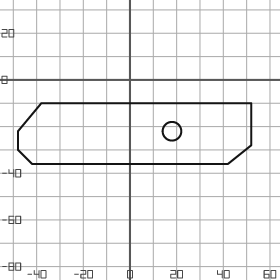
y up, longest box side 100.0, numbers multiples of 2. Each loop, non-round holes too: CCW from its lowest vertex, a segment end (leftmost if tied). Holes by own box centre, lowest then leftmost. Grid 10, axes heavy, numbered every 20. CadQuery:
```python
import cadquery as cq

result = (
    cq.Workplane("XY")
    .moveTo(-42.0, -36.0)
    .lineTo(42.0, -36.0)
    .lineTo(52.0, -28.0)
    .lineTo(52.0, -10.0)
    .lineTo(-38.0, -10.0)
    .lineTo(-48.0, -22.0)
    .lineTo(-48.0, -30.0)
    .close()
    .moveTo(18.0, -22.0)
    .circle(4.0)
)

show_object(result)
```